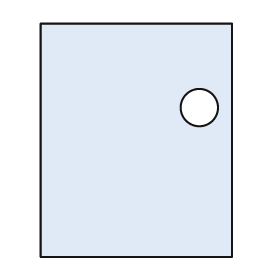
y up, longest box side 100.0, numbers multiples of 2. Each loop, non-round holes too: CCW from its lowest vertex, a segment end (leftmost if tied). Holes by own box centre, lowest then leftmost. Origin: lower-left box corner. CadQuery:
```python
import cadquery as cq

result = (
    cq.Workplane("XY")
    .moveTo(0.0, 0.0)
    .lineTo(82.0, 0.0)
    .lineTo(82.0, 100.0)
    .lineTo(0.0, 100.0)
    .close()
    .moveTo(68.0, 64.0)
    .circle(8.0)
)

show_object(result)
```